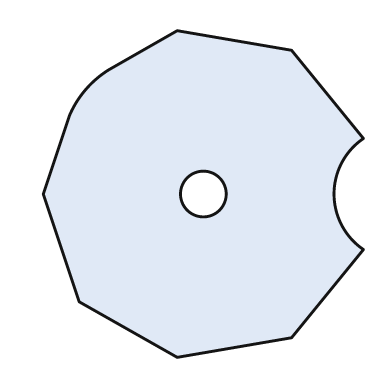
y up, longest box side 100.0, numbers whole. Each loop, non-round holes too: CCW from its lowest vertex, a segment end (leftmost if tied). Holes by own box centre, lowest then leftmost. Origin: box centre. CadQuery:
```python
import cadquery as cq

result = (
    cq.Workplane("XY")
    .moveTo(-8.0, -50.0)
    .lineTo(27.0, -44.0)
    .lineTo(49.0, -17.0)
    .threePointArc((40.0, 0.0), (49.0, 17.0))
    .lineTo(27.0, 44.0)
    .lineTo(-8.0, 50.0)
    .lineTo(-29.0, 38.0)
    .threePointArc((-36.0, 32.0), (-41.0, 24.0))
    .lineTo(-49.0, 0.0)
    .lineTo(-38.0, -33.0)
    .close()
    .moveTo(0.0, 0.0)
    .circle(7.0)
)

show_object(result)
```